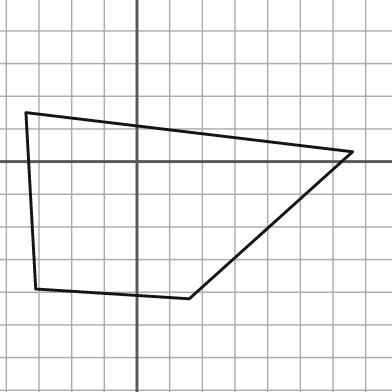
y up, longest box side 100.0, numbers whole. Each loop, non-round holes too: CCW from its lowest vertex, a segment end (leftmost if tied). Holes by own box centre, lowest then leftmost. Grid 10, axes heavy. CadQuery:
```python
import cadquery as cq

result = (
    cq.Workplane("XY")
    .moveTo(16.0, -42.0)
    .lineTo(66.0, 3.0)
    .lineTo(-34.0, 15.0)
    .lineTo(-31.0, -39.0)
    .close()
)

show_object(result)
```